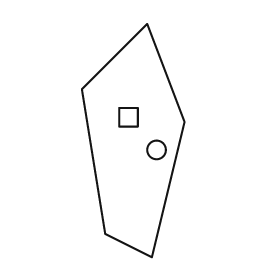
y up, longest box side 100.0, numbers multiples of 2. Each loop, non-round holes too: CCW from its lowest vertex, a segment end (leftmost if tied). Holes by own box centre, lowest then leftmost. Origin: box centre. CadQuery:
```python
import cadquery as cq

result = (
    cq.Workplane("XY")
    .moveTo(8.0, -50.0)
    .lineTo(22.0, 8.0)
    .lineTo(6.0, 50.0)
    .lineTo(-22.0, 22.0)
    .lineTo(-12.0, -40.0)
    .close()
    .moveTo(10.0, -4.0)
    .circle(4.0)
    .moveTo(-6.0, 6.0)
    .lineTo(2.0, 6.0)
    .lineTo(2.0, 14.0)
    .lineTo(-6.0, 14.0)
    .close()
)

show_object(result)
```